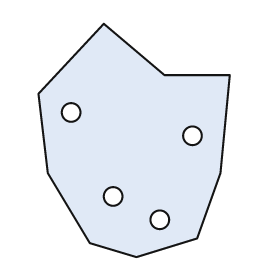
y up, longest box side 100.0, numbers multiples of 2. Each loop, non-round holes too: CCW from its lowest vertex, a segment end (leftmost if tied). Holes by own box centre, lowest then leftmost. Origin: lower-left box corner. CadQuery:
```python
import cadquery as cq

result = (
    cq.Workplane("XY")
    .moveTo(42.0, 0.0)
    .lineTo(68.0, 8.0)
    .lineTo(78.0, 36.0)
    .lineTo(82.0, 78.0)
    .lineTo(54.0, 78.0)
    .lineTo(28.0, 100.0)
    .lineTo(0.0, 70.0)
    .lineTo(4.0, 36.0)
    .lineTo(22.0, 6.0)
    .close()
    .moveTo(52.0, 16.0)
    .circle(4.0)
    .moveTo(32.0, 26.0)
    .circle(4.0)
    .moveTo(66.0, 52.0)
    .circle(4.0)
    .moveTo(14.0, 62.0)
    .circle(4.0)
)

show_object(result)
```